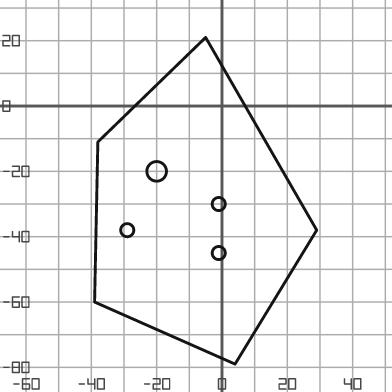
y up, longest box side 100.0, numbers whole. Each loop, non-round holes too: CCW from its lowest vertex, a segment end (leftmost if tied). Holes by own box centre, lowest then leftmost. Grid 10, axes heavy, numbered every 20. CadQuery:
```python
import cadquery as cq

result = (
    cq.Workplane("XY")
    .moveTo(4.0, -79.0)
    .lineTo(29.0, -38.0)
    .lineTo(-5.0, 21.0)
    .lineTo(-38.0, -11.0)
    .lineTo(-39.0, -60.0)
    .close()
    .moveTo(-1.0, -45.0)
    .circle(2.0)
    .moveTo(-29.0, -38.0)
    .circle(2.0)
    .moveTo(-1.0, -30.0)
    .circle(2.0)
    .moveTo(-20.0, -20.0)
    .circle(3.0)
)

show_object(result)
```